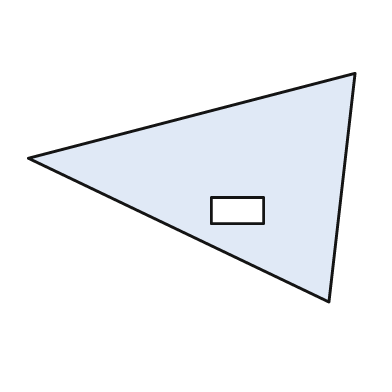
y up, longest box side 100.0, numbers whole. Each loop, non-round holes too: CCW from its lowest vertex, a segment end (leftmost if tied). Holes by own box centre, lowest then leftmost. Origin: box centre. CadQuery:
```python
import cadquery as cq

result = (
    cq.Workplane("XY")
    .moveTo(42.0, -35.0)
    .lineTo(50.0, 35.0)
    .lineTo(-50.0, 9.0)
    .close()
    .moveTo(6.0, -11.0)
    .lineTo(22.0, -11.0)
    .lineTo(22.0, -3.0)
    .lineTo(6.0, -3.0)
    .close()
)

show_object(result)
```